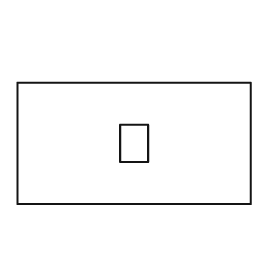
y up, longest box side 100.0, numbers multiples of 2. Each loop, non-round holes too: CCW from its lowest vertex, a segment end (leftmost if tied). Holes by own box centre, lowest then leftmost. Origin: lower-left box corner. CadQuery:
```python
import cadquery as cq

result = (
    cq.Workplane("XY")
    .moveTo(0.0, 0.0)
    .lineTo(100.0, 0.0)
    .lineTo(100.0, 52.0)
    .lineTo(0.0, 52.0)
    .close()
    .moveTo(44.0, 18.0)
    .lineTo(56.0, 18.0)
    .lineTo(56.0, 34.0)
    .lineTo(44.0, 34.0)
    .close()
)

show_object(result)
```